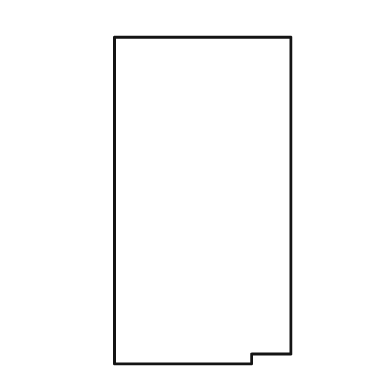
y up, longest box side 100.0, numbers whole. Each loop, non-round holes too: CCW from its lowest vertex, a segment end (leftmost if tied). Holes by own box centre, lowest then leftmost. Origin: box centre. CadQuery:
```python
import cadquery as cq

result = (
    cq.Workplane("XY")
    .moveTo(-27.0, -50.0)
    .lineTo(15.0, -50.0)
    .lineTo(15.0, -47.0)
    .lineTo(27.0, -47.0)
    .lineTo(27.0, 50.0)
    .lineTo(-27.0, 50.0)
    .close()
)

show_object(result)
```